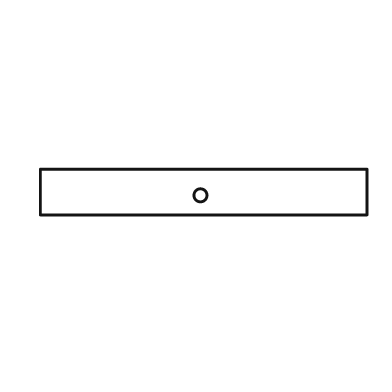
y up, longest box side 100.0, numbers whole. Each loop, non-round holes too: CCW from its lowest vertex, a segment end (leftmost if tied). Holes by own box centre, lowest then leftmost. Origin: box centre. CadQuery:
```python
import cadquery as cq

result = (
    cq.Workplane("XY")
    .moveTo(-50.0, -7.0)
    .lineTo(50.0, -7.0)
    .lineTo(50.0, 7.0)
    .lineTo(-50.0, 7.0)
    .close()
    .moveTo(-1.0, -1.0)
    .circle(2.0)
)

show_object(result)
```